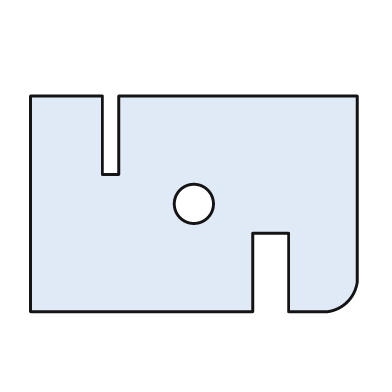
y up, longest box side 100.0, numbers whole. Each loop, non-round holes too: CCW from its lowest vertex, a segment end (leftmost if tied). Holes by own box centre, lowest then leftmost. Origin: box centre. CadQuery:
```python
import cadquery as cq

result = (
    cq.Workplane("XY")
    .moveTo(-50.0, -33.0)
    .lineTo(18.0, -33.0)
    .lineTo(18.0, -9.0)
    .lineTo(29.0, -9.0)
    .lineTo(29.0, -33.0)
    .lineTo(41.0, -33.0)
    .threePointArc((47.0, -30.0), (50.0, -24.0))
    .lineTo(50.0, 33.0)
    .lineTo(-23.0, 33.0)
    .lineTo(-23.0, 9.0)
    .lineTo(-28.0, 9.0)
    .lineTo(-28.0, 33.0)
    .lineTo(-50.0, 33.0)
    .close()
    .moveTo(0.0, 0.0)
    .circle(6.0)
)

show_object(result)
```